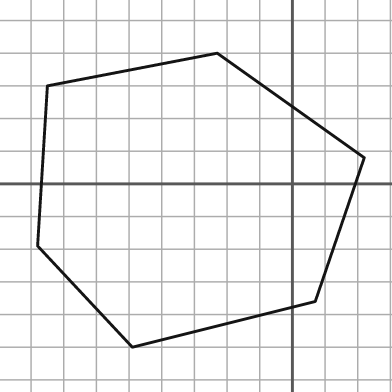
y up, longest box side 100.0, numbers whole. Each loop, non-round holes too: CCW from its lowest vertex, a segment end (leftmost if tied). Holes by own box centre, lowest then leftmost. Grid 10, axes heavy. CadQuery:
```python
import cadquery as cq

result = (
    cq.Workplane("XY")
    .moveTo(-49.0, -50.0)
    .lineTo(7.0, -36.0)
    .lineTo(22.0, 8.0)
    .lineTo(-23.0, 40.0)
    .lineTo(-75.0, 30.0)
    .lineTo(-78.0, -19.0)
    .close()
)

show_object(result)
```